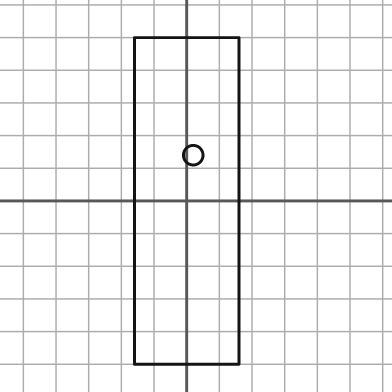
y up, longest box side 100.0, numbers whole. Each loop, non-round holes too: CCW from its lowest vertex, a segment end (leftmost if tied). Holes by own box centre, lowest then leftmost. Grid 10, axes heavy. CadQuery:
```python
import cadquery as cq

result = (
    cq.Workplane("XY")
    .moveTo(-16.0, -50.0)
    .lineTo(16.0, -50.0)
    .lineTo(16.0, 50.0)
    .lineTo(-16.0, 50.0)
    .close()
    .moveTo(2.0, 14.0)
    .circle(3.0)
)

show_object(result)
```